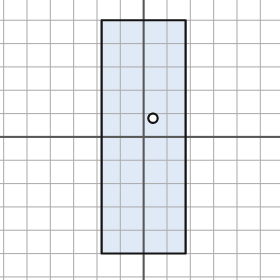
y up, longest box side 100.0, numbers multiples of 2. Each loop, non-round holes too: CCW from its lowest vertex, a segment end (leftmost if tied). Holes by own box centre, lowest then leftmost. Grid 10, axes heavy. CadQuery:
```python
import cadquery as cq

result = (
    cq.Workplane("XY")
    .moveTo(-18.0, -50.0)
    .lineTo(18.0, -50.0)
    .lineTo(18.0, 50.0)
    .lineTo(-18.0, 50.0)
    .close()
    .moveTo(4.0, 8.0)
    .circle(2.0)
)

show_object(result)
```